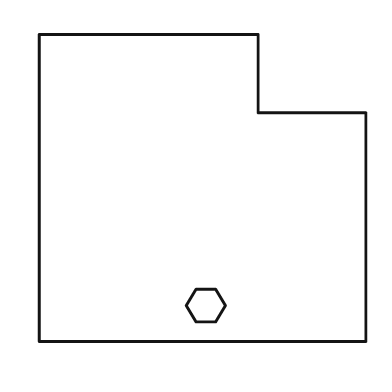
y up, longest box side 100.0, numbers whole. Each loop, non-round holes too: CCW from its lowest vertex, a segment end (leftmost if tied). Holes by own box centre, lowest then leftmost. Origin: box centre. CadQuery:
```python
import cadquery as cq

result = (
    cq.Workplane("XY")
    .moveTo(-50.0, -47.0)
    .lineTo(50.0, -47.0)
    .lineTo(50.0, 23.0)
    .lineTo(17.0, 23.0)
    .lineTo(17.0, 47.0)
    .lineTo(-50.0, 47.0)
    .close()
    .moveTo(-2.0, -41.0)
    .lineTo(4.0, -41.0)
    .lineTo(7.0, -36.0)
    .lineTo(4.0, -31.0)
    .lineTo(-2.0, -31.0)
    .lineTo(-5.0, -36.0)
    .close()
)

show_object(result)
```